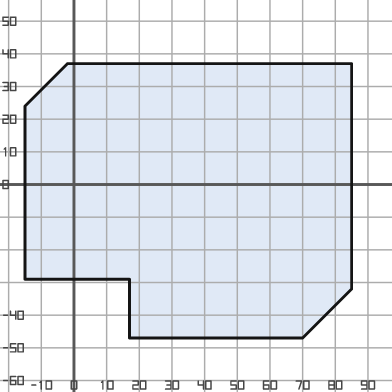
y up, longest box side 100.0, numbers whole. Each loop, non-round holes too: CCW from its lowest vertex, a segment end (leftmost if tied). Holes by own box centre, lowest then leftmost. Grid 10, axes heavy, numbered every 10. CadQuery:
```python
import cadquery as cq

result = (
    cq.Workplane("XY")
    .moveTo(17.0, -47.0)
    .lineTo(70.0, -47.0)
    .lineTo(85.0, -32.0)
    .lineTo(85.0, 37.0)
    .lineTo(-2.0, 37.0)
    .lineTo(-15.0, 24.0)
    .lineTo(-15.0, -29.0)
    .lineTo(17.0, -29.0)
    .close()
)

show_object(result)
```